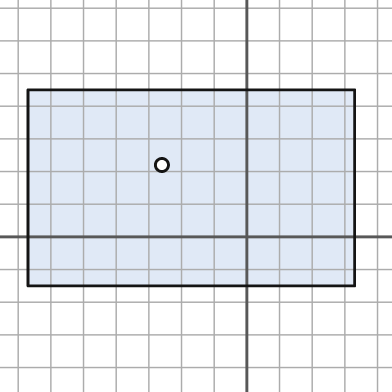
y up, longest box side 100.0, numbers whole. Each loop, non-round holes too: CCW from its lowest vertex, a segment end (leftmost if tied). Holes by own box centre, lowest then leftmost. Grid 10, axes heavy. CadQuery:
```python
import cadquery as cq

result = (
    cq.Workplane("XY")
    .moveTo(-67.0, -15.0)
    .lineTo(33.0, -15.0)
    .lineTo(33.0, 45.0)
    .lineTo(-67.0, 45.0)
    .close()
    .moveTo(-26.0, 22.0)
    .circle(2.0)
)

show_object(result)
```